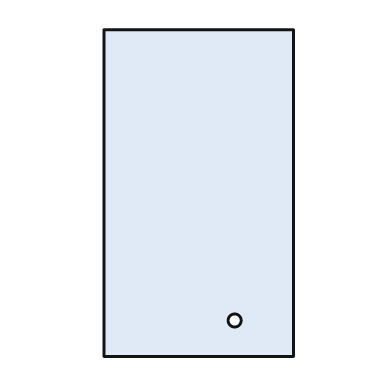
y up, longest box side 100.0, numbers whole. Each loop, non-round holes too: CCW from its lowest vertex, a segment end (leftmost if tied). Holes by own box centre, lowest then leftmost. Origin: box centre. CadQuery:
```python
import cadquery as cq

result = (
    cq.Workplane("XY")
    .moveTo(-29.0, -50.0)
    .lineTo(29.0, -50.0)
    .lineTo(29.0, 50.0)
    .lineTo(-29.0, 50.0)
    .close()
    .moveTo(11.0, -39.0)
    .circle(2.0)
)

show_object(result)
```